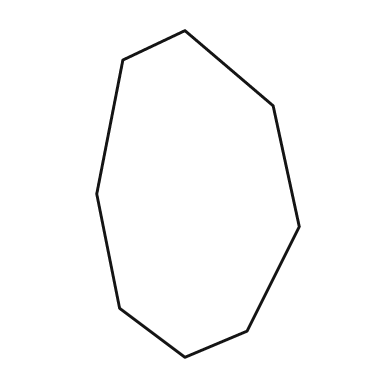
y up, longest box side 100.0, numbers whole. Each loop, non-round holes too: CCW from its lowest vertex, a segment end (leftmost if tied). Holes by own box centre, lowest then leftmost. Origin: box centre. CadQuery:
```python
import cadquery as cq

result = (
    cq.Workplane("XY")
    .moveTo(-4.0, -50.0)
    .lineTo(15.0, -42.0)
    .lineTo(31.0, -10.0)
    .lineTo(23.0, 27.0)
    .lineTo(-4.0, 50.0)
    .lineTo(-23.0, 41.0)
    .lineTo(-31.0, 0.0)
    .lineTo(-24.0, -35.0)
    .close()
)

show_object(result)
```